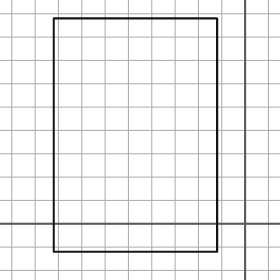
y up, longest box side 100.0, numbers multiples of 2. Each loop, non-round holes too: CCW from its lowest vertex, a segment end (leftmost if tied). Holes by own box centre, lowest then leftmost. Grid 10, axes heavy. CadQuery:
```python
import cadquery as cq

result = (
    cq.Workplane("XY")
    .moveTo(-82.0, -12.0)
    .lineTo(-12.0, -12.0)
    .lineTo(-12.0, 88.0)
    .lineTo(-82.0, 88.0)
    .close()
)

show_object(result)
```